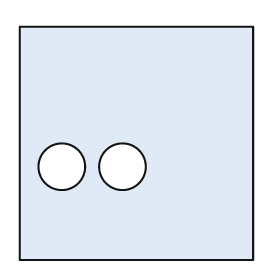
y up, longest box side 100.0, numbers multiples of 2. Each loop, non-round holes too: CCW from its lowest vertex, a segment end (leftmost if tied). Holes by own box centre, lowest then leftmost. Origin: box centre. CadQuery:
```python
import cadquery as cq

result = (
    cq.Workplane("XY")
    .moveTo(-50.0, -50.0)
    .lineTo(50.0, -50.0)
    .lineTo(50.0, 50.0)
    .lineTo(-50.0, 50.0)
    .close()
    .moveTo(-32.0, -10.0)
    .circle(10.0)
    .moveTo(-6.0, -10.0)
    .circle(10.0)
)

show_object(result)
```